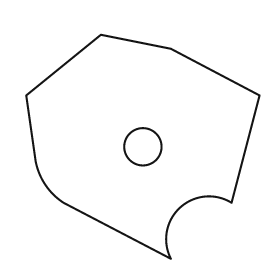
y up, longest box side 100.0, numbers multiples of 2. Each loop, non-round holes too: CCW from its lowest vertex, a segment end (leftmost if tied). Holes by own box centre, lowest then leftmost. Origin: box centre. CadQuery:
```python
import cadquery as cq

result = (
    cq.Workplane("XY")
    .moveTo(12.0, -48.0)
    .threePointArc((16.0, -26.0), (38.0, -24.0))
    .lineTo(50.0, 22.0)
    .lineTo(12.0, 42.0)
    .lineTo(-18.0, 48.0)
    .lineTo(-50.0, 22.0)
    .lineTo(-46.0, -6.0)
    .threePointArc((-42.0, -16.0), (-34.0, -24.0))
    .close()
    .moveTo(0.0, 0.0)
    .circle(8.0)
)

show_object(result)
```